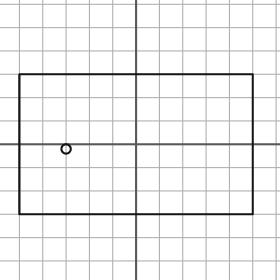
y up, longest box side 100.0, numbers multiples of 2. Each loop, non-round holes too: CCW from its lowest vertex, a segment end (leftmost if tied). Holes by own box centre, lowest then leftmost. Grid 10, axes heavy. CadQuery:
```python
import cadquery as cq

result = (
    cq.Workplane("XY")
    .moveTo(-50.0, -30.0)
    .lineTo(50.0, -30.0)
    .lineTo(50.0, 30.0)
    .lineTo(-50.0, 30.0)
    .close()
    .moveTo(-30.0, -2.0)
    .circle(2.0)
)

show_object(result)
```